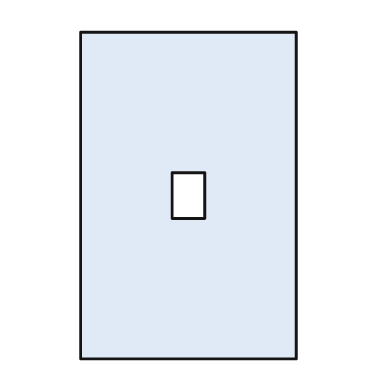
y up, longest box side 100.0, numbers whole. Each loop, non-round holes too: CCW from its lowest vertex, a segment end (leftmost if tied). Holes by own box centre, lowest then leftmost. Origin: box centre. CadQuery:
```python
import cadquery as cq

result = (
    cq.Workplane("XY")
    .moveTo(-33.0, -50.0)
    .lineTo(33.0, -50.0)
    .lineTo(33.0, 50.0)
    .lineTo(-33.0, 50.0)
    .close()
    .moveTo(-5.0, -7.0)
    .lineTo(5.0, -7.0)
    .lineTo(5.0, 7.0)
    .lineTo(-5.0, 7.0)
    .close()
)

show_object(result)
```